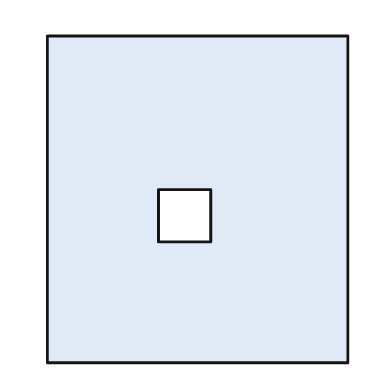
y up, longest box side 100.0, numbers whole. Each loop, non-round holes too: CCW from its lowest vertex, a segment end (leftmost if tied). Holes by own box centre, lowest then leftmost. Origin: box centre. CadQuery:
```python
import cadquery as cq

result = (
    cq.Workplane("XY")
    .moveTo(-46.0, -50.0)
    .lineTo(46.0, -50.0)
    .lineTo(46.0, 50.0)
    .lineTo(-46.0, 50.0)
    .close()
    .moveTo(-12.0, -13.0)
    .lineTo(4.0, -13.0)
    .lineTo(4.0, 3.0)
    .lineTo(-12.0, 3.0)
    .close()
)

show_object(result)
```